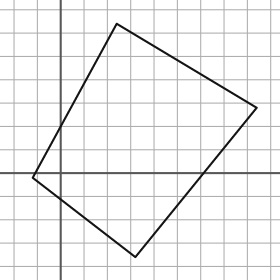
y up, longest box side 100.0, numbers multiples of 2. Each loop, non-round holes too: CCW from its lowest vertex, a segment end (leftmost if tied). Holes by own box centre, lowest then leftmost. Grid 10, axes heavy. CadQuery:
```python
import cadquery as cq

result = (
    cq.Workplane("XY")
    .moveTo(32.0, -36.0)
    .lineTo(84.0, 28.0)
    .lineTo(24.0, 64.0)
    .lineTo(-12.0, -2.0)
    .close()
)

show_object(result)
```